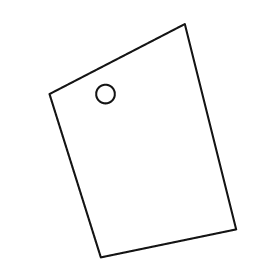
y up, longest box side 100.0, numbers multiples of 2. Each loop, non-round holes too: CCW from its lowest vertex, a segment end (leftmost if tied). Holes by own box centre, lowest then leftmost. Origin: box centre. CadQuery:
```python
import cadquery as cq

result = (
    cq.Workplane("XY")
    .moveTo(-18.0, -50.0)
    .lineTo(40.0, -38.0)
    .lineTo(18.0, 50.0)
    .lineTo(-40.0, 20.0)
    .close()
    .moveTo(-16.0, 20.0)
    .circle(4.0)
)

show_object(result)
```